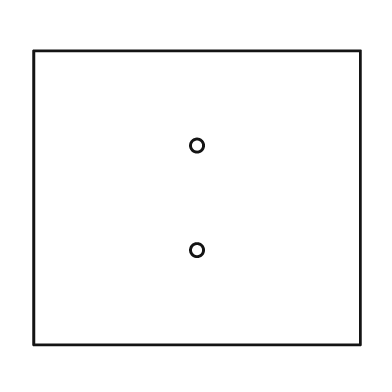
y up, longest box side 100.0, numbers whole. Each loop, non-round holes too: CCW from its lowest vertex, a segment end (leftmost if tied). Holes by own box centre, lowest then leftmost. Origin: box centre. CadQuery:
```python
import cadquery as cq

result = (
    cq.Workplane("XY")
    .moveTo(-50.0, -45.0)
    .lineTo(50.0, -45.0)
    .lineTo(50.0, 45.0)
    .lineTo(-50.0, 45.0)
    .close()
    .moveTo(0.0, -16.0)
    .circle(2.0)
    .moveTo(0.0, 16.0)
    .circle(2.0)
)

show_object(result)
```